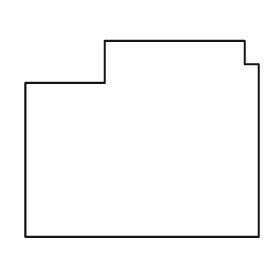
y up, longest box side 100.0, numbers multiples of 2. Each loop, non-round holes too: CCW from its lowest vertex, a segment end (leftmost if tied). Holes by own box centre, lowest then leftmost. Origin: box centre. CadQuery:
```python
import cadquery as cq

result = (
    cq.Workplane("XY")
    .moveTo(-50.0, -42.0)
    .lineTo(50.0, -42.0)
    .lineTo(50.0, 32.0)
    .lineTo(44.0, 32.0)
    .lineTo(44.0, 42.0)
    .lineTo(-16.0, 42.0)
    .lineTo(-16.0, 24.0)
    .lineTo(-50.0, 24.0)
    .close()
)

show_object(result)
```